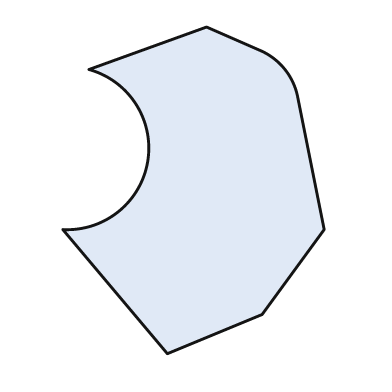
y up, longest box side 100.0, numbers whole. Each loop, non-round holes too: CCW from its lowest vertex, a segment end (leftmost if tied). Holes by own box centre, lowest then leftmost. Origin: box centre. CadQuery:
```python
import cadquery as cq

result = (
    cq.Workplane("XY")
    .moveTo(-8.0, -50.0)
    .lineTo(21.0, -38.0)
    .lineTo(40.0, -12.0)
    .lineTo(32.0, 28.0)
    .threePointArc((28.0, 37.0), (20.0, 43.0))
    .lineTo(4.0, 50.0)
    .lineTo(-32.0, 37.0)
    .threePointArc((-14.0, 9.0), (-40.0, -12.0))
    .close()
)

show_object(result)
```